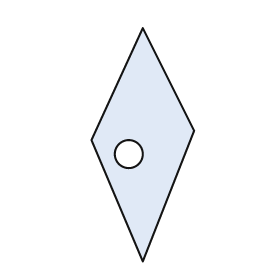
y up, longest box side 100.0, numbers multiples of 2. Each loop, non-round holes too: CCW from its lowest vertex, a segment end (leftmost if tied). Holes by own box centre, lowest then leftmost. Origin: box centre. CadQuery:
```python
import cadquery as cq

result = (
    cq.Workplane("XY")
    .moveTo(0.0, -50.0)
    .lineTo(22.0, 6.0)
    .lineTo(0.0, 50.0)
    .lineTo(-22.0, 2.0)
    .close()
    .moveTo(-6.0, -4.0)
    .circle(6.0)
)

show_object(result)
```